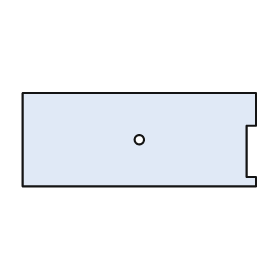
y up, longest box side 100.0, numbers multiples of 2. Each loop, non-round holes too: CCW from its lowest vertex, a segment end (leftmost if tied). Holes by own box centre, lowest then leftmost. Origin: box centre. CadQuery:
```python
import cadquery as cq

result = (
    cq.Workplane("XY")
    .moveTo(-50.0, -20.0)
    .lineTo(50.0, -20.0)
    .lineTo(50.0, -16.0)
    .lineTo(46.0, -16.0)
    .lineTo(46.0, 6.0)
    .lineTo(50.0, 6.0)
    .lineTo(50.0, 20.0)
    .lineTo(-50.0, 20.0)
    .close()
    .moveTo(0.0, 0.0)
    .circle(2.0)
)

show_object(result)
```